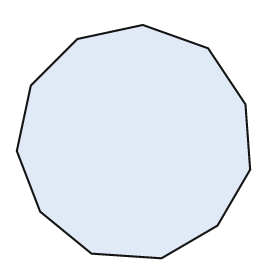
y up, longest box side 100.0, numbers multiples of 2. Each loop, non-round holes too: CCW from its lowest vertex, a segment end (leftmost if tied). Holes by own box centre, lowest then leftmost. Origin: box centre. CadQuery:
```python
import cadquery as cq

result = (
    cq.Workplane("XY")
    .moveTo(12.0, -50.0)
    .lineTo(36.0, -36.0)
    .lineTo(50.0, -12.0)
    .lineTo(48.0, 16.0)
    .lineTo(32.0, 40.0)
    .lineTo(4.0, 50.0)
    .lineTo(-24.0, 44.0)
    .lineTo(-44.0, 24.0)
    .lineTo(-50.0, -4.0)
    .lineTo(-40.0, -30.0)
    .lineTo(-18.0, -48.0)
    .close()
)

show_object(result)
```